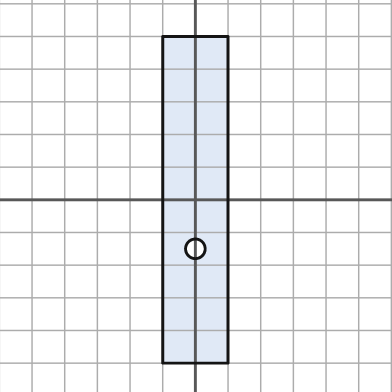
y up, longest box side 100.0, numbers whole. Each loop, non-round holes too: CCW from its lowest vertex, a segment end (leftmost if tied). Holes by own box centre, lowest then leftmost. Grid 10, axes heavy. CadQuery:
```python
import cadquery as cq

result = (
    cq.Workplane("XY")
    .moveTo(-10.0, -50.0)
    .lineTo(10.0, -50.0)
    .lineTo(10.0, 50.0)
    .lineTo(-10.0, 50.0)
    .close()
    .moveTo(0.0, -15.0)
    .circle(3.0)
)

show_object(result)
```